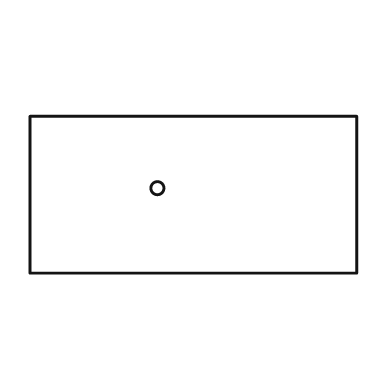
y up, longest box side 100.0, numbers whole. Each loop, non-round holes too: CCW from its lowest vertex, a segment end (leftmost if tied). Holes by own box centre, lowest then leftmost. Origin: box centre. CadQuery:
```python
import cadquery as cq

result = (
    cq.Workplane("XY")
    .moveTo(-50.0, -24.0)
    .lineTo(50.0, -24.0)
    .lineTo(50.0, 24.0)
    .lineTo(-50.0, 24.0)
    .close()
    .moveTo(-11.0, 2.0)
    .circle(2.0)
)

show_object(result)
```